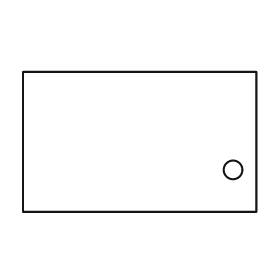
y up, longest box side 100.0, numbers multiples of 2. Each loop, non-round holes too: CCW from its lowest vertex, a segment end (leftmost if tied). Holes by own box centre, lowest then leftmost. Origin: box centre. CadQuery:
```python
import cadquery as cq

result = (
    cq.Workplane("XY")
    .moveTo(-50.0, -30.0)
    .lineTo(50.0, -30.0)
    .lineTo(50.0, 30.0)
    .lineTo(-50.0, 30.0)
    .close()
    .moveTo(40.0, -12.0)
    .circle(4.0)
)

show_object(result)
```